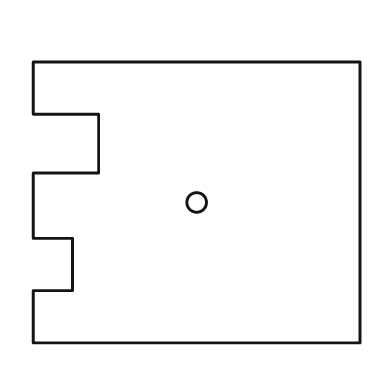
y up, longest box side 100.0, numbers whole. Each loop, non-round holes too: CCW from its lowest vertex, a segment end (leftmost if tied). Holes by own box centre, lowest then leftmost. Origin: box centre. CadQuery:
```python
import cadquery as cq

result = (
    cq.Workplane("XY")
    .moveTo(-50.0, -43.0)
    .lineTo(50.0, -43.0)
    .lineTo(50.0, 43.0)
    .lineTo(-50.0, 43.0)
    .lineTo(-50.0, 27.0)
    .lineTo(-30.0, 27.0)
    .lineTo(-30.0, 9.0)
    .lineTo(-50.0, 9.0)
    .lineTo(-50.0, -11.0)
    .lineTo(-38.0, -11.0)
    .lineTo(-38.0, -27.0)
    .lineTo(-50.0, -27.0)
    .close()
    .moveTo(0.0, 0.0)
    .circle(3.0)
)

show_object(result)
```